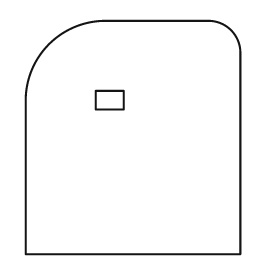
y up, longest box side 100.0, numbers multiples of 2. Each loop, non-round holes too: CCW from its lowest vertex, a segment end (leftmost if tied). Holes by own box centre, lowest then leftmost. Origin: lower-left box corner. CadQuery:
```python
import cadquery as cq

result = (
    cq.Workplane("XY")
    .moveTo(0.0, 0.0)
    .lineTo(92.0, 0.0)
    .lineTo(92.0, 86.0)
    .threePointArc((88.0, 96.0), (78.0, 100.0))
    .lineTo(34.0, 100.0)
    .threePointArc((10.0, 90.0), (0.0, 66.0))
    .close()
    .moveTo(30.0, 62.0)
    .lineTo(42.0, 62.0)
    .lineTo(42.0, 70.0)
    .lineTo(30.0, 70.0)
    .close()
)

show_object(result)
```